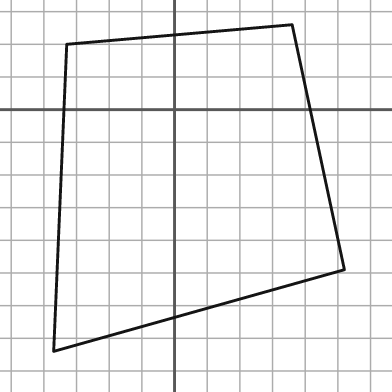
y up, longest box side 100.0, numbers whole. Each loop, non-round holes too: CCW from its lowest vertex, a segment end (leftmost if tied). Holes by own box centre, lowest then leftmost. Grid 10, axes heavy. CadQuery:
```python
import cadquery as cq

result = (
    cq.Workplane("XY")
    .moveTo(-37.0, -74.0)
    .lineTo(52.0, -49.0)
    .lineTo(36.0, 26.0)
    .lineTo(-33.0, 20.0)
    .close()
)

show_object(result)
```